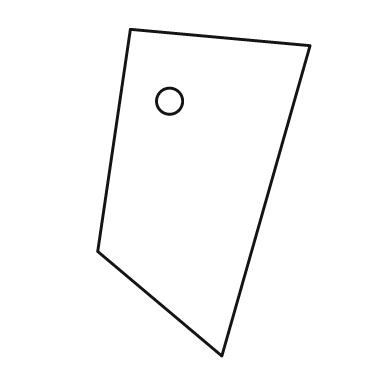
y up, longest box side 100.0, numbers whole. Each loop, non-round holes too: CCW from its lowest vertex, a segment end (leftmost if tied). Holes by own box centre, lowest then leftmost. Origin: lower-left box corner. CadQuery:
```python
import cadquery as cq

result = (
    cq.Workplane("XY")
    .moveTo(38.0, 0.0)
    .lineTo(65.0, 95.0)
    .lineTo(10.0, 100.0)
    .lineTo(0.0, 32.0)
    .close()
    .moveTo(22.0, 78.0)
    .circle(4.0)
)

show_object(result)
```